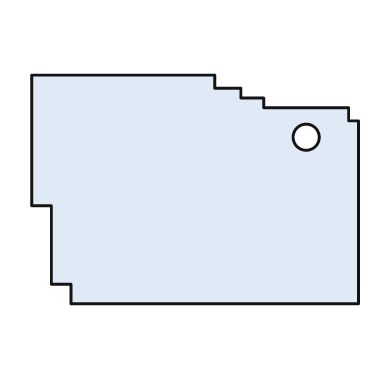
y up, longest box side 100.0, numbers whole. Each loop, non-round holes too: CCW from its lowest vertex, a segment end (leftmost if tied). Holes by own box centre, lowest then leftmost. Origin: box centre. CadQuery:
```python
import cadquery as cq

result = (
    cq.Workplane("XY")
    .moveTo(-38.0, -35.0)
    .lineTo(50.0, -35.0)
    .lineTo(50.0, 21.0)
    .lineTo(47.0, 21.0)
    .lineTo(47.0, 25.0)
    .lineTo(21.0, 25.0)
    .lineTo(21.0, 28.0)
    .lineTo(14.0, 28.0)
    .lineTo(14.0, 31.0)
    .lineTo(6.0, 31.0)
    .lineTo(6.0, 35.0)
    .lineTo(-50.0, 35.0)
    .lineTo(-50.0, -5.0)
    .lineTo(-44.0, -5.0)
    .lineTo(-44.0, -29.0)
    .lineTo(-38.0, -29.0)
    .close()
    .moveTo(34.0, 16.0)
    .circle(4.0)
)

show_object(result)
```